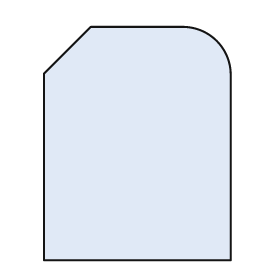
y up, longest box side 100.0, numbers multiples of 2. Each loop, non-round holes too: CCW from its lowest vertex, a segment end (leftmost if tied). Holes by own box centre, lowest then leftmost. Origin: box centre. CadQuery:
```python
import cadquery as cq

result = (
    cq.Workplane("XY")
    .moveTo(-40.0, -50.0)
    .lineTo(40.0, -50.0)
    .lineTo(40.0, 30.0)
    .threePointArc((34.0, 44.0), (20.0, 50.0))
    .lineTo(-20.0, 50.0)
    .lineTo(-40.0, 30.0)
    .close()
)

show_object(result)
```